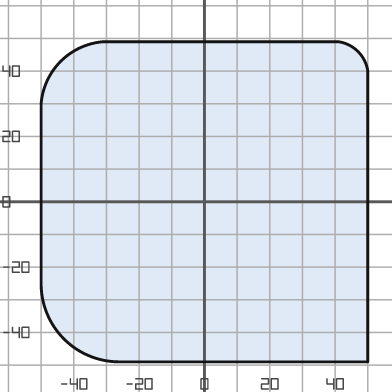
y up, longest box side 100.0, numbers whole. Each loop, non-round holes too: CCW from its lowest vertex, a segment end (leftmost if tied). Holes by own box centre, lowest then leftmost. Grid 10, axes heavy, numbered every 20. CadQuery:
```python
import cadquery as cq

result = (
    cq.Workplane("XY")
    .moveTo(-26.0, -49.0)
    .lineTo(50.0, -49.0)
    .lineTo(50.0, 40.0)
    .threePointArc((47.0, 46.0), (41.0, 49.0))
    .lineTo(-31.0, 49.0)
    .threePointArc((-44.0, 43.0), (-50.0, 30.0))
    .lineTo(-50.0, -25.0)
    .threePointArc((-43.0, -42.0), (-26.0, -49.0))
    .close()
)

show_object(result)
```